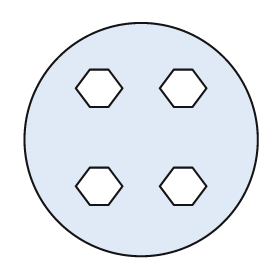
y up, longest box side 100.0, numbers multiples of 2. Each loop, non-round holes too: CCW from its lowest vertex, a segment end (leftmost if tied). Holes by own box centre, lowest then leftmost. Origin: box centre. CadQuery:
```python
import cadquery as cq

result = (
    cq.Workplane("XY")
    .moveTo(0.0, 0.0)
    .circle(50.0)
    .moveTo(-22.0, -28.0)
    .lineTo(-14.0, -28.0)
    .lineTo(-8.0, -20.0)
    .lineTo(-14.0, -12.0)
    .lineTo(-22.0, -12.0)
    .lineTo(-28.0, -20.0)
    .close()
    .moveTo(14.0, -28.0)
    .lineTo(22.0, -28.0)
    .lineTo(28.0, -20.0)
    .lineTo(22.0, -12.0)
    .lineTo(14.0, -12.0)
    .lineTo(8.0, -20.0)
    .close()
    .moveTo(-22.0, 14.0)
    .lineTo(-14.0, 14.0)
    .lineTo(-8.0, 22.0)
    .lineTo(-14.0, 30.0)
    .lineTo(-22.0, 30.0)
    .lineTo(-28.0, 22.0)
    .close()
    .moveTo(14.0, 14.0)
    .lineTo(22.0, 14.0)
    .lineTo(28.0, 22.0)
    .lineTo(22.0, 30.0)
    .lineTo(14.0, 30.0)
    .lineTo(8.0, 22.0)
    .close()
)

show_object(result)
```